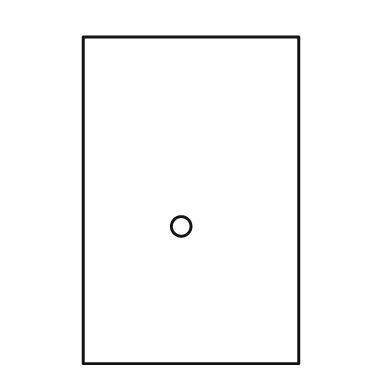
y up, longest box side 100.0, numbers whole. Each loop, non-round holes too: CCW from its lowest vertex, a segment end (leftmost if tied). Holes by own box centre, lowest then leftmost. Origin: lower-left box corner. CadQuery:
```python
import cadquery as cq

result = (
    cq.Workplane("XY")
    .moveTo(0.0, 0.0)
    .lineTo(66.0, 0.0)
    .lineTo(66.0, 100.0)
    .lineTo(0.0, 100.0)
    .close()
    .moveTo(30.0, 42.0)
    .circle(3.0)
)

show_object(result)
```